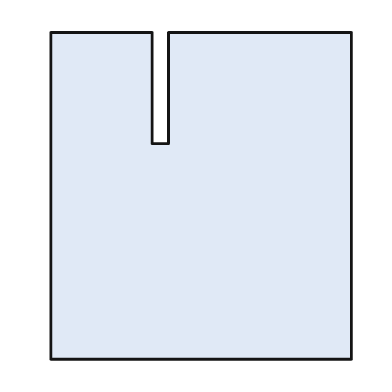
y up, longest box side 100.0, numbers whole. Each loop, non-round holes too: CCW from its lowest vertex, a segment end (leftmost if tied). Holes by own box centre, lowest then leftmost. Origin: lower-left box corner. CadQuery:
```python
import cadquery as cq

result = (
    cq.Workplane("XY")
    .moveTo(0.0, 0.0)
    .lineTo(92.0, 0.0)
    .lineTo(92.0, 100.0)
    .lineTo(36.0, 100.0)
    .lineTo(36.0, 66.0)
    .lineTo(31.0, 66.0)
    .lineTo(31.0, 100.0)
    .lineTo(0.0, 100.0)
    .close()
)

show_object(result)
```